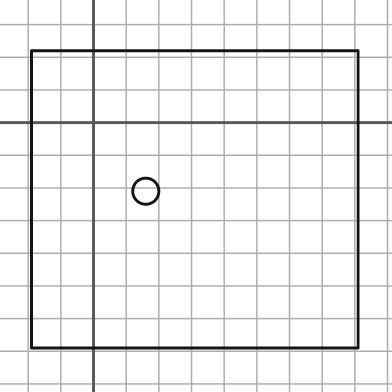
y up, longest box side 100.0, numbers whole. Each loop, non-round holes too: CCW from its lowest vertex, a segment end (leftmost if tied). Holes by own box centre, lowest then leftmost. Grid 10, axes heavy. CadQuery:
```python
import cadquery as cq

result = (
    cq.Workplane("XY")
    .moveTo(-19.0, -69.0)
    .lineTo(81.0, -69.0)
    .lineTo(81.0, 22.0)
    .lineTo(-19.0, 22.0)
    .close()
    .moveTo(16.0, -21.0)
    .circle(4.0)
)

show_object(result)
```